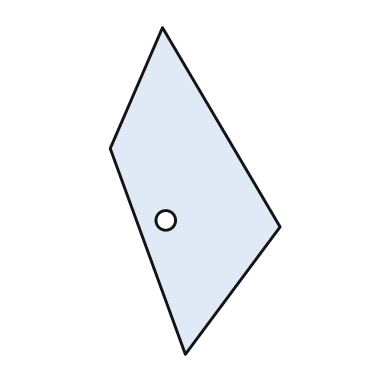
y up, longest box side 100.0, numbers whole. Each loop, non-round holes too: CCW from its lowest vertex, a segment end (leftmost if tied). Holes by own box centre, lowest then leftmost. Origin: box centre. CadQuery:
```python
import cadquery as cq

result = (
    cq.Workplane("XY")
    .moveTo(-3.0, -50.0)
    .lineTo(26.0, -11.0)
    .lineTo(-10.0, 50.0)
    .lineTo(-26.0, 13.0)
    .close()
    .moveTo(-9.0, -9.0)
    .circle(3.0)
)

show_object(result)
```